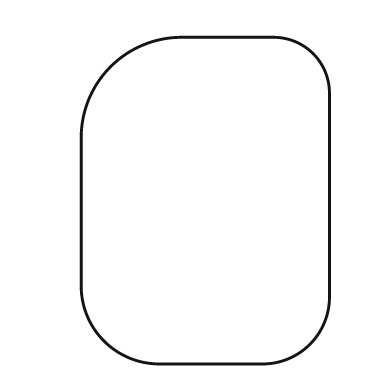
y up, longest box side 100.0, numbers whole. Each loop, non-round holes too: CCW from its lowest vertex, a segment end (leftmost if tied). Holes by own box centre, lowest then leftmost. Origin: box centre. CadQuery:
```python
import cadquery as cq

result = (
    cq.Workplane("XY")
    .moveTo(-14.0, -50.0)
    .lineTo(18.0, -50.0)
    .threePointArc((32.0, -44.0), (38.0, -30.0))
    .lineTo(38.0, 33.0)
    .threePointArc((33.0, 45.0), (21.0, 50.0))
    .lineTo(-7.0, 50.0)
    .threePointArc((-29.0, 41.0), (-38.0, 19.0))
    .lineTo(-38.0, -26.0)
    .threePointArc((-31.0, -43.0), (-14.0, -50.0))
    .close()
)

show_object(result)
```